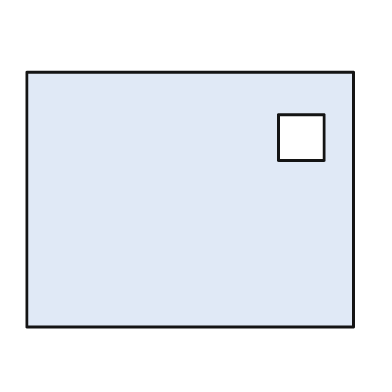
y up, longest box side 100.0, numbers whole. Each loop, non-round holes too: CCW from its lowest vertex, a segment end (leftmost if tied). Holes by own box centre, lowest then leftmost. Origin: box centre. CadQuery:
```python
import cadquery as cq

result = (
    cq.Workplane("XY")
    .moveTo(-50.0, -39.0)
    .lineTo(50.0, -39.0)
    .lineTo(50.0, 39.0)
    .lineTo(-50.0, 39.0)
    .close()
    .moveTo(27.0, 12.0)
    .lineTo(41.0, 12.0)
    .lineTo(41.0, 26.0)
    .lineTo(27.0, 26.0)
    .close()
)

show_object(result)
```